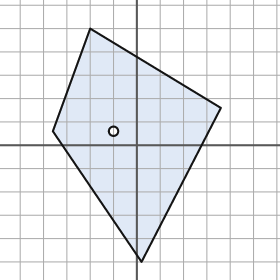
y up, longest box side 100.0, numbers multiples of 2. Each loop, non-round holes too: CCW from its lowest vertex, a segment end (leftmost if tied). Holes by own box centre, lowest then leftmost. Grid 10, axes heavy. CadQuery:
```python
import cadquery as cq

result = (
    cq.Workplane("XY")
    .moveTo(2.0, -50.0)
    .lineTo(36.0, 16.0)
    .lineTo(-20.0, 50.0)
    .lineTo(-36.0, 6.0)
    .close()
    .moveTo(-10.0, 6.0)
    .circle(2.0)
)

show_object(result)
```